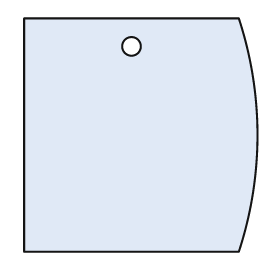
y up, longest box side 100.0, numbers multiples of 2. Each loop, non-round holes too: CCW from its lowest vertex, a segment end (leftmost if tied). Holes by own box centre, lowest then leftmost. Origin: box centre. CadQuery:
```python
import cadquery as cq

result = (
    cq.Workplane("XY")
    .moveTo(-50.0, -50.0)
    .lineTo(42.0, -50.0)
    .threePointArc((50.0, 0.0), (42.0, 50.0))
    .lineTo(-50.0, 50.0)
    .close()
    .moveTo(-4.0, 38.0)
    .circle(4.0)
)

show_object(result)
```